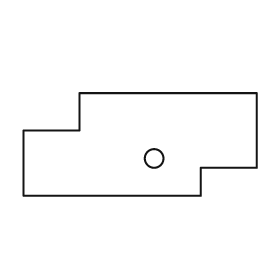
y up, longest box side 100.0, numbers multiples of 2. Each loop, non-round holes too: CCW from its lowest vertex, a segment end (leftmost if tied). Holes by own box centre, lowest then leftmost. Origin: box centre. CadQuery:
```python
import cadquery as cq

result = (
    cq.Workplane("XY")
    .moveTo(-50.0, -22.0)
    .lineTo(26.0, -22.0)
    .lineTo(26.0, -10.0)
    .lineTo(50.0, -10.0)
    .lineTo(50.0, 22.0)
    .lineTo(-26.0, 22.0)
    .lineTo(-26.0, 6.0)
    .lineTo(-50.0, 6.0)
    .close()
    .moveTo(6.0, -6.0)
    .circle(4.0)
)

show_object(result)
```